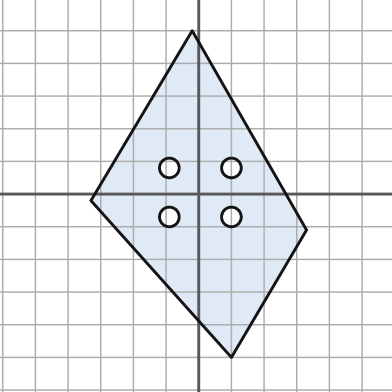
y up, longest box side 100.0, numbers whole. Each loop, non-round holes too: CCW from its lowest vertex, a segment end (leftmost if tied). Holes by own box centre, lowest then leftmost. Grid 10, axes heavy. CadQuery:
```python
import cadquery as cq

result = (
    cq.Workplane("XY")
    .moveTo(10.0, -50.0)
    .lineTo(33.0, -11.0)
    .lineTo(-2.0, 50.0)
    .lineTo(-33.0, -2.0)
    .close()
    .moveTo(-9.0, -7.0)
    .circle(3.0)
    .moveTo(10.0, -7.0)
    .circle(3.0)
    .moveTo(-9.0, 8.0)
    .circle(3.0)
    .moveTo(10.0, 8.0)
    .circle(3.0)
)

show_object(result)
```